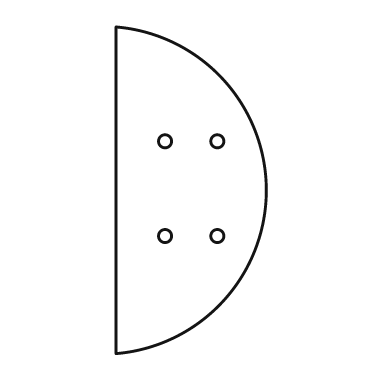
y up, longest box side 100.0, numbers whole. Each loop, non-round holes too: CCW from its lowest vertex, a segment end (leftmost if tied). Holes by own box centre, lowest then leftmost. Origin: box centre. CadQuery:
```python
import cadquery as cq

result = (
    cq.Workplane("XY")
    .moveTo(-23.0, -50.0)
    .threePointArc((23.0, 0.0), (-23.0, 50.0))
    .close()
    .moveTo(-8.0, -14.0)
    .circle(2.0)
    .moveTo(8.0, -14.0)
    .circle(2.0)
    .moveTo(-8.0, 15.0)
    .circle(2.0)
    .moveTo(8.0, 15.0)
    .circle(2.0)
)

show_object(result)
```